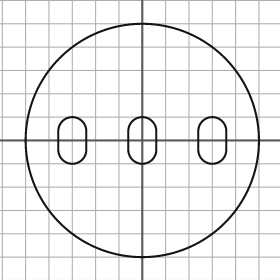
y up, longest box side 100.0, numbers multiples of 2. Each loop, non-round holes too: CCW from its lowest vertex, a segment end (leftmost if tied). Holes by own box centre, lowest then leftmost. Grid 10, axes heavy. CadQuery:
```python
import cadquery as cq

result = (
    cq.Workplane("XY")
    .moveTo(0.0, 0.0)
    .circle(50.0)
    .moveTo(-36.0, -4.0)
    .threePointArc((-30.0, -10.0), (-24.0, -4.0))
    .lineTo(-24.0, 4.0)
    .threePointArc((-30.0, 10.0), (-36.0, 4.0))
    .close()
    .moveTo(-6.0, -4.0)
    .threePointArc((0.0, -10.0), (6.0, -4.0))
    .lineTo(6.0, 4.0)
    .threePointArc((0.0, 10.0), (-6.0, 4.0))
    .close()
    .moveTo(24.0, -4.0)
    .threePointArc((30.0, -10.0), (36.0, -4.0))
    .lineTo(36.0, 4.0)
    .threePointArc((30.0, 10.0), (24.0, 4.0))
    .close()
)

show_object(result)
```